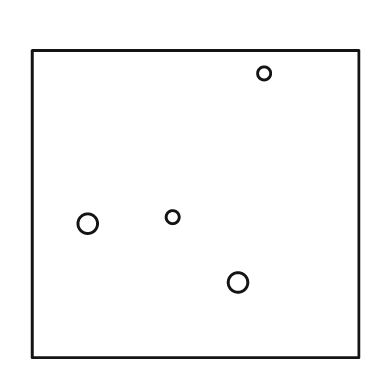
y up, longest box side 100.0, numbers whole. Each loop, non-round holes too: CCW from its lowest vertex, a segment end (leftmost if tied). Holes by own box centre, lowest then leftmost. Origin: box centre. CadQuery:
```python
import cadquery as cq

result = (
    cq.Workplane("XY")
    .moveTo(-50.0, -47.0)
    .lineTo(50.0, -47.0)
    .lineTo(50.0, 47.0)
    .lineTo(-50.0, 47.0)
    .close()
    .moveTo(13.0, -24.0)
    .circle(3.0)
    .moveTo(-33.0, -6.0)
    .circle(3.0)
    .moveTo(-7.0, -4.0)
    .circle(2.0)
    .moveTo(21.0, 40.0)
    .circle(2.0)
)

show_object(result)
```